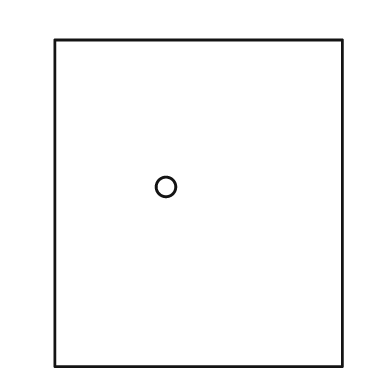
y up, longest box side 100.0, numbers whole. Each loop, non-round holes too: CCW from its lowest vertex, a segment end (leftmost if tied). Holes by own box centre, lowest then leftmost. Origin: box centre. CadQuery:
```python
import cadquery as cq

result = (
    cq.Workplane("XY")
    .moveTo(-44.0, -50.0)
    .lineTo(44.0, -50.0)
    .lineTo(44.0, 50.0)
    .lineTo(-44.0, 50.0)
    .close()
    .moveTo(-10.0, 5.0)
    .circle(3.0)
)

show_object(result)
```